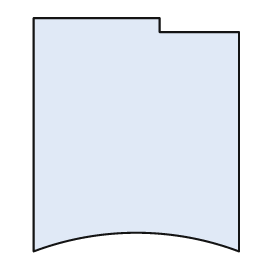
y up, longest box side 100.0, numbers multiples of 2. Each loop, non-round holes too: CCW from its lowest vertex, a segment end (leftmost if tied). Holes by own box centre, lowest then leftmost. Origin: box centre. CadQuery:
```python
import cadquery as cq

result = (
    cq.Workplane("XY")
    .moveTo(-44.0, -50.0)
    .threePointArc((0.0, -42.0), (44.0, -50.0))
    .lineTo(44.0, 44.0)
    .lineTo(10.0, 44.0)
    .lineTo(10.0, 50.0)
    .lineTo(-44.0, 50.0)
    .close()
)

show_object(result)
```